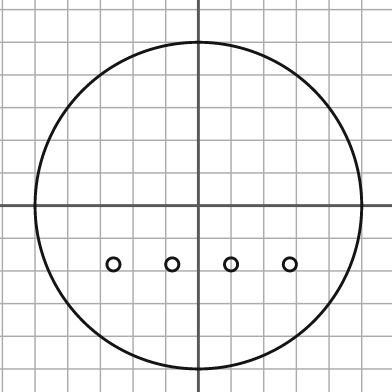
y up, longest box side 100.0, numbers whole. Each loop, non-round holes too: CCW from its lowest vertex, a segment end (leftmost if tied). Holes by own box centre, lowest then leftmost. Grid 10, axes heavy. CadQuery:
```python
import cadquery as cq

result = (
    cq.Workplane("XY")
    .moveTo(0.0, 0.0)
    .circle(50.0)
    .moveTo(-26.0, -18.0)
    .circle(2.0)
    .moveTo(-8.0, -18.0)
    .circle(2.0)
    .moveTo(10.0, -18.0)
    .circle(2.0)
    .moveTo(28.0, -18.0)
    .circle(2.0)
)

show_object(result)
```